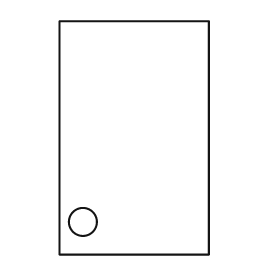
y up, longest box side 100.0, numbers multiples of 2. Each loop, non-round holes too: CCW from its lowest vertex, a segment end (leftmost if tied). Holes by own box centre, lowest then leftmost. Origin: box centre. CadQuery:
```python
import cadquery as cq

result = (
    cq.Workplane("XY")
    .moveTo(-32.0, -50.0)
    .lineTo(32.0, -50.0)
    .lineTo(32.0, 50.0)
    .lineTo(-32.0, 50.0)
    .close()
    .moveTo(-22.0, -36.0)
    .circle(6.0)
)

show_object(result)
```